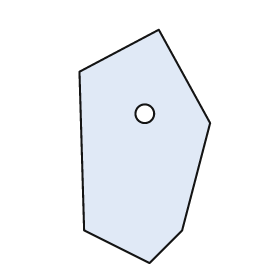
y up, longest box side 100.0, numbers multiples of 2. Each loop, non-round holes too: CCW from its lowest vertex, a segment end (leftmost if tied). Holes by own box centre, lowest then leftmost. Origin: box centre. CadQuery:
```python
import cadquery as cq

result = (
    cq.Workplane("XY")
    .moveTo(2.0, -50.0)
    .lineTo(16.0, -36.0)
    .lineTo(28.0, 10.0)
    .lineTo(6.0, 50.0)
    .lineTo(-28.0, 32.0)
    .lineTo(-26.0, -36.0)
    .close()
    .moveTo(0.0, 14.0)
    .circle(4.0)
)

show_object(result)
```